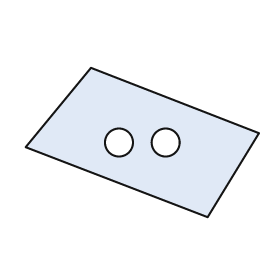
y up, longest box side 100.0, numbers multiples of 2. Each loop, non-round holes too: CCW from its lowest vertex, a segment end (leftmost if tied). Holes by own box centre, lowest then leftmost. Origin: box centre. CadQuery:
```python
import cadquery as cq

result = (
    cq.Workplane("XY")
    .moveTo(28.0, -32.0)
    .lineTo(50.0, 4.0)
    .lineTo(-22.0, 32.0)
    .lineTo(-50.0, -2.0)
    .close()
    .moveTo(-10.0, 0.0)
    .circle(6.0)
    .moveTo(10.0, 0.0)
    .circle(6.0)
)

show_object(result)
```